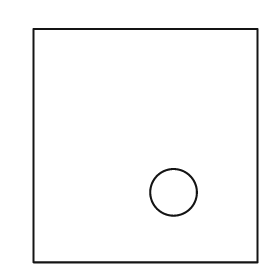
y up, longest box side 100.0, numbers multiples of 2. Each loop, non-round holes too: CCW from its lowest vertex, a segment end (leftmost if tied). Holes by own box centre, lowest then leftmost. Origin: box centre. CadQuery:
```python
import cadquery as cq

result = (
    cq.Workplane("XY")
    .moveTo(-48.0, -50.0)
    .lineTo(48.0, -50.0)
    .lineTo(48.0, 50.0)
    .lineTo(-48.0, 50.0)
    .close()
    .moveTo(12.0, -20.0)
    .circle(10.0)
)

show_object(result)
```